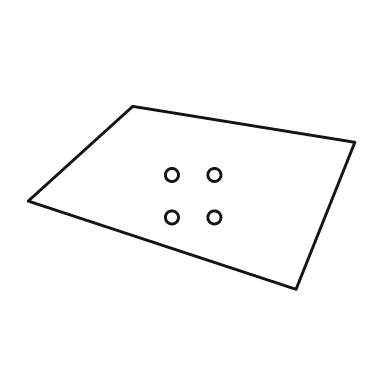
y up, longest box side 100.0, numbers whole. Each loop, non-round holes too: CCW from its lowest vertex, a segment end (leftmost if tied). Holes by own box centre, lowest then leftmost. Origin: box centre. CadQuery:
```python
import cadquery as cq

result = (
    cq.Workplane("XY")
    .moveTo(32.0, -28.0)
    .lineTo(50.0, 17.0)
    .lineTo(-18.0, 28.0)
    .lineTo(-50.0, -1.0)
    .close()
    .moveTo(-6.0, -6.0)
    .circle(2.0)
    .moveTo(7.0, -6.0)
    .circle(2.0)
    .moveTo(-6.0, 7.0)
    .circle(2.0)
    .moveTo(7.0, 7.0)
    .circle(2.0)
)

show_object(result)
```